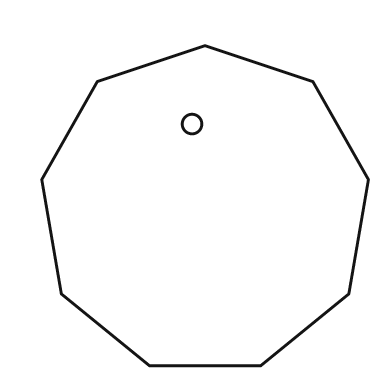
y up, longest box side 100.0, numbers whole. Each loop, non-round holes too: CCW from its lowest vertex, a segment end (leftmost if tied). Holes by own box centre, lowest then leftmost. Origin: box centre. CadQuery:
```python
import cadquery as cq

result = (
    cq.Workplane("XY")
    .moveTo(-17.0, -49.0)
    .lineTo(17.0, -49.0)
    .lineTo(44.0, -27.0)
    .lineTo(50.0, 8.0)
    .lineTo(33.0, 38.0)
    .lineTo(0.0, 49.0)
    .lineTo(-33.0, 38.0)
    .lineTo(-50.0, 8.0)
    .lineTo(-44.0, -27.0)
    .close()
    .moveTo(-4.0, 25.0)
    .circle(3.0)
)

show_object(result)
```